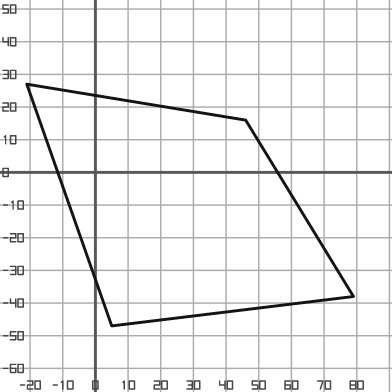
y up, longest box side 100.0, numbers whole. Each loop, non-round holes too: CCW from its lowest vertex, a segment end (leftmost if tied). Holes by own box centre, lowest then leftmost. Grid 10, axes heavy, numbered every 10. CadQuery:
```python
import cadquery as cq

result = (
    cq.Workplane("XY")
    .moveTo(5.0, -47.0)
    .lineTo(79.0, -38.0)
    .lineTo(46.0, 16.0)
    .lineTo(-21.0, 27.0)
    .close()
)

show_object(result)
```